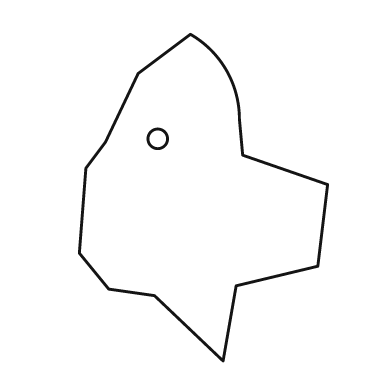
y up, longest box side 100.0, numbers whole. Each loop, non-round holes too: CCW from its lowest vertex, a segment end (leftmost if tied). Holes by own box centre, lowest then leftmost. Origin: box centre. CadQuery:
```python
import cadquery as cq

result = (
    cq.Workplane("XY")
    .moveTo(6.0, -50.0)
    .lineTo(10.0, -27.0)
    .lineTo(35.0, -21.0)
    .lineTo(38.0, 4.0)
    .lineTo(12.0, 13.0)
    .lineTo(11.0, 24.0)
    .threePointArc((7.0, 39.0), (-4.0, 50.0))
    .lineTo(-20.0, 38.0)
    .lineTo(-30.0, 17.0)
    .lineTo(-36.0, 9.0)
    .lineTo(-38.0, -17.0)
    .lineTo(-29.0, -28.0)
    .lineTo(-15.0, -30.0)
    .close()
    .moveTo(-14.0, 18.0)
    .circle(3.0)
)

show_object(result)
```